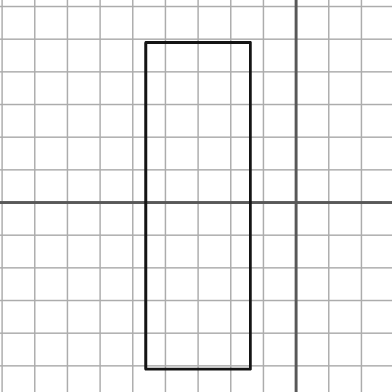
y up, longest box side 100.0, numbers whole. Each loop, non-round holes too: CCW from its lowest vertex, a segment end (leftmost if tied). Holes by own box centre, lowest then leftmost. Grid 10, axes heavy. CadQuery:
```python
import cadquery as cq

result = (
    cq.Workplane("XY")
    .moveTo(-46.0, -51.0)
    .lineTo(-14.0, -51.0)
    .lineTo(-14.0, 49.0)
    .lineTo(-46.0, 49.0)
    .close()
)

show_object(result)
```